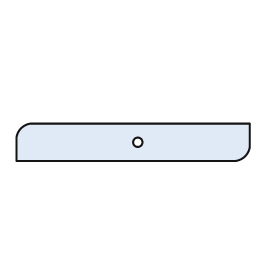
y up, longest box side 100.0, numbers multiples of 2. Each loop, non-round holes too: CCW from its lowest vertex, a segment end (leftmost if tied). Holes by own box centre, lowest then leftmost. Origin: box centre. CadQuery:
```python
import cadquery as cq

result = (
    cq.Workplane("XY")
    .moveTo(-50.0, -8.0)
    .lineTo(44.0, -8.0)
    .threePointArc((48.0, -6.0), (50.0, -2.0))
    .lineTo(50.0, 8.0)
    .lineTo(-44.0, 8.0)
    .threePointArc((-48.0, 6.0), (-50.0, 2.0))
    .close()
    .moveTo(2.0, 0.0)
    .circle(2.0)
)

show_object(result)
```